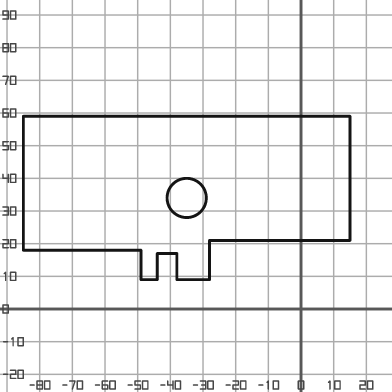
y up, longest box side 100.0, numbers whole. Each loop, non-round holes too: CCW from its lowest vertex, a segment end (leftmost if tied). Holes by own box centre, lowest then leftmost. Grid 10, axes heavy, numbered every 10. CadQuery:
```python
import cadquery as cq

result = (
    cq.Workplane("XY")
    .moveTo(-49.0, 9.0)
    .lineTo(-44.0, 9.0)
    .lineTo(-44.0, 17.0)
    .lineTo(-38.0, 17.0)
    .lineTo(-38.0, 9.0)
    .lineTo(-28.0, 9.0)
    .lineTo(-28.0, 21.0)
    .lineTo(15.0, 21.0)
    .lineTo(15.0, 59.0)
    .lineTo(-85.0, 59.0)
    .lineTo(-85.0, 18.0)
    .lineTo(-49.0, 18.0)
    .close()
    .moveTo(-35.0, 34.0)
    .circle(6.0)
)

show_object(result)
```